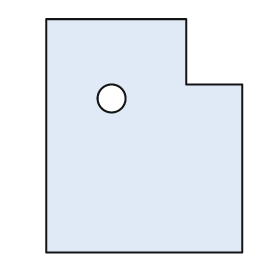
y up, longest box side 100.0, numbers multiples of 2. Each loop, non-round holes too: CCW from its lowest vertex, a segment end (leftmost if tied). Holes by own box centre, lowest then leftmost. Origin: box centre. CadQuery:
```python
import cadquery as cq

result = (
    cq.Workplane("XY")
    .moveTo(-42.0, -50.0)
    .lineTo(42.0, -50.0)
    .lineTo(42.0, 22.0)
    .lineTo(18.0, 22.0)
    .lineTo(18.0, 50.0)
    .lineTo(-42.0, 50.0)
    .close()
    .moveTo(-14.0, 16.0)
    .circle(6.0)
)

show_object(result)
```